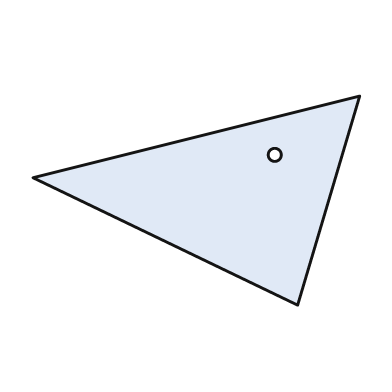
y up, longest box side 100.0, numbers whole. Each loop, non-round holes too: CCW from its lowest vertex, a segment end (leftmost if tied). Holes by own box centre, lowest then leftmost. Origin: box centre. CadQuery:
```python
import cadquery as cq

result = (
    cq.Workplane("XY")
    .moveTo(31.0, -32.0)
    .lineTo(50.0, 32.0)
    .lineTo(-50.0, 7.0)
    .close()
    .moveTo(24.0, 14.0)
    .circle(2.0)
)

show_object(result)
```